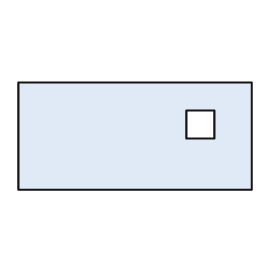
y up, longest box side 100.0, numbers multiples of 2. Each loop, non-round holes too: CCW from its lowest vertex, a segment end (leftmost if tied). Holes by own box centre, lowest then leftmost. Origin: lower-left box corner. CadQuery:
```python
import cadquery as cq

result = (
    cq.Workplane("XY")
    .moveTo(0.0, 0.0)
    .lineTo(100.0, 0.0)
    .lineTo(100.0, 46.0)
    .lineTo(0.0, 46.0)
    .close()
    .moveTo(72.0, 22.0)
    .lineTo(84.0, 22.0)
    .lineTo(84.0, 34.0)
    .lineTo(72.0, 34.0)
    .close()
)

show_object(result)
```